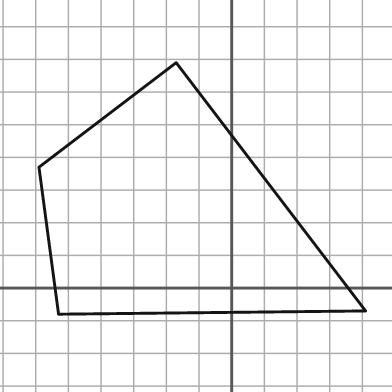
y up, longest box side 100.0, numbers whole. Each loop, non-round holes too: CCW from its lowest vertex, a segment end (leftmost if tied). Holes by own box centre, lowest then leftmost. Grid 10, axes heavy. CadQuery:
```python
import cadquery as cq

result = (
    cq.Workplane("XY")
    .moveTo(-53.0, -8.0)
    .lineTo(41.0, -7.0)
    .lineTo(-17.0, 69.0)
    .lineTo(-59.0, 37.0)
    .close()
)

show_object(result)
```